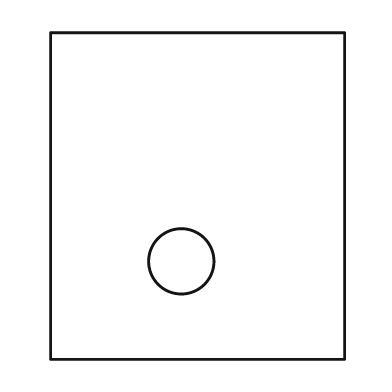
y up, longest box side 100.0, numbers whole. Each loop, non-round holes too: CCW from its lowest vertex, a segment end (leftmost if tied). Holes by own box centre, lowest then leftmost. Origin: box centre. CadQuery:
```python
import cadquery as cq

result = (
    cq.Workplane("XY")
    .moveTo(-45.0, -50.0)
    .lineTo(45.0, -50.0)
    .lineTo(45.0, 50.0)
    .lineTo(-45.0, 50.0)
    .close()
    .moveTo(-5.0, -20.0)
    .circle(10.0)
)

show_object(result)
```